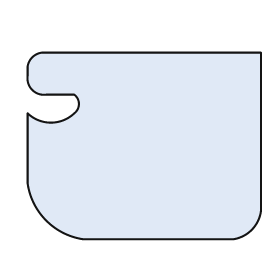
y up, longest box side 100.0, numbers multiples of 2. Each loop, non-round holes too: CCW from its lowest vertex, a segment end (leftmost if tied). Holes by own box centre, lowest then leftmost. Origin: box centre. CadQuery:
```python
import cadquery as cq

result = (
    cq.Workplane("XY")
    .moveTo(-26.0, -40.0)
    .lineTo(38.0, -40.0)
    .threePointArc((46.0, -36.0), (50.0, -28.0))
    .lineTo(50.0, 40.0)
    .lineTo(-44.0, 40.0)
    .threePointArc((-48.0, 38.0), (-50.0, 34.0))
    .lineTo(-50.0, 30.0)
    .threePointArc((-48.0, 24.0), (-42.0, 22.0))
    .lineTo(-30.0, 22.0)
    .threePointArc((-28.0, 18.0), (-30.0, 14.0))
    .threePointArc((-40.0, 10.0), (-50.0, 14.0))
    .lineTo(-50.0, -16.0)
    .threePointArc((-42.0, -32.0), (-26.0, -40.0))
    .close()
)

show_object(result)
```